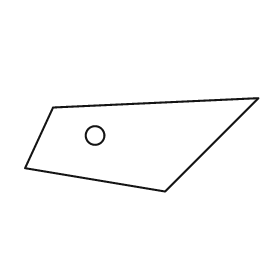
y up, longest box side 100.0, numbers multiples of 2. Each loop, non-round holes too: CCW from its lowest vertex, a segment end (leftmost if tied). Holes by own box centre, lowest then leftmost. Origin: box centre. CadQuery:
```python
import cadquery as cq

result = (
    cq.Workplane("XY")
    .moveTo(10.0, -20.0)
    .lineTo(50.0, 20.0)
    .lineTo(-38.0, 16.0)
    .lineTo(-50.0, -10.0)
    .close()
    .moveTo(-20.0, 4.0)
    .circle(4.0)
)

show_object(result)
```